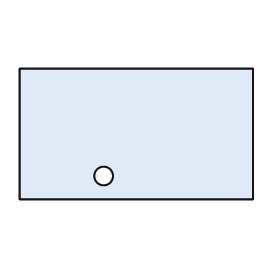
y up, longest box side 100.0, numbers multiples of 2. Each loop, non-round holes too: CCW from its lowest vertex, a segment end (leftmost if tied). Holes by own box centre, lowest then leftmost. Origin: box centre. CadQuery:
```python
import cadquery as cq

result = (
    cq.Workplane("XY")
    .moveTo(-50.0, -28.0)
    .lineTo(50.0, -28.0)
    .lineTo(50.0, 28.0)
    .lineTo(-50.0, 28.0)
    .close()
    .moveTo(-14.0, -18.0)
    .circle(4.0)
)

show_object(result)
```